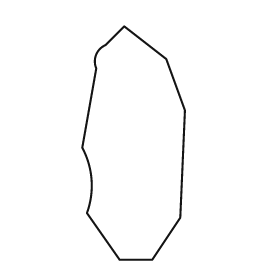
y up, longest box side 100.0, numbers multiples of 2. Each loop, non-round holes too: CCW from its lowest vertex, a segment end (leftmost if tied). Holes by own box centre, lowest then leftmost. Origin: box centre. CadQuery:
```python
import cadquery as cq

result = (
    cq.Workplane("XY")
    .moveTo(-6.0, -50.0)
    .lineTo(8.0, -50.0)
    .lineTo(20.0, -32.0)
    .lineTo(22.0, 14.0)
    .lineTo(14.0, 36.0)
    .lineTo(-4.0, 50.0)
    .lineTo(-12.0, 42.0)
    .threePointArc((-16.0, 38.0), (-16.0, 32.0))
    .lineTo(-22.0, -2.0)
    .threePointArc((-18.0, -16.0), (-20.0, -30.0))
    .close()
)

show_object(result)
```